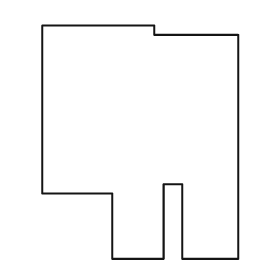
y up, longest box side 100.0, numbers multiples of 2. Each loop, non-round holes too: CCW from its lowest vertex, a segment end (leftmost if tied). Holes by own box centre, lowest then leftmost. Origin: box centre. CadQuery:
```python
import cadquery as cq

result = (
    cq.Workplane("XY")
    .moveTo(-12.0, -50.0)
    .lineTo(10.0, -50.0)
    .lineTo(10.0, -18.0)
    .lineTo(18.0, -18.0)
    .lineTo(18.0, -50.0)
    .lineTo(42.0, -50.0)
    .lineTo(42.0, 46.0)
    .lineTo(6.0, 46.0)
    .lineTo(6.0, 50.0)
    .lineTo(-42.0, 50.0)
    .lineTo(-42.0, -22.0)
    .lineTo(-12.0, -22.0)
    .close()
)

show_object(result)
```